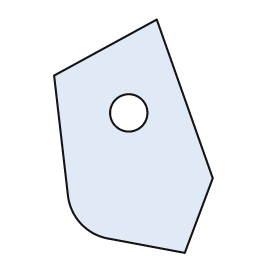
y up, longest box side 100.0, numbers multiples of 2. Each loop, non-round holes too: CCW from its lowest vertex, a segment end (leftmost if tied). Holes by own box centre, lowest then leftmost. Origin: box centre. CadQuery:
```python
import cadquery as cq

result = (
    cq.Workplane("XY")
    .moveTo(22.0, -50.0)
    .lineTo(34.0, -18.0)
    .lineTo(10.0, 50.0)
    .lineTo(-34.0, 26.0)
    .lineTo(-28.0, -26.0)
    .threePointArc((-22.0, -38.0), (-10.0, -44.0))
    .close()
    .moveTo(-2.0, 10.0)
    .circle(8.0)
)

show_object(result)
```